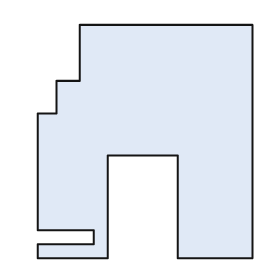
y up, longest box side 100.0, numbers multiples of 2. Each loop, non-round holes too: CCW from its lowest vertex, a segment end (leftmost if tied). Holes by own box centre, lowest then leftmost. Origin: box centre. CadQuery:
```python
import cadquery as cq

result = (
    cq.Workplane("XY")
    .moveTo(-46.0, -50.0)
    .lineTo(-16.0, -50.0)
    .lineTo(-16.0, -6.0)
    .lineTo(14.0, -6.0)
    .lineTo(14.0, -50.0)
    .lineTo(46.0, -50.0)
    .lineTo(46.0, 50.0)
    .lineTo(-28.0, 50.0)
    .lineTo(-28.0, 26.0)
    .lineTo(-38.0, 26.0)
    .lineTo(-38.0, 12.0)
    .lineTo(-46.0, 12.0)
    .lineTo(-46.0, -38.0)
    .lineTo(-22.0, -38.0)
    .lineTo(-22.0, -44.0)
    .lineTo(-46.0, -44.0)
    .close()
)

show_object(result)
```